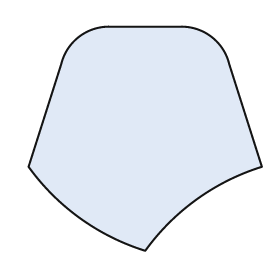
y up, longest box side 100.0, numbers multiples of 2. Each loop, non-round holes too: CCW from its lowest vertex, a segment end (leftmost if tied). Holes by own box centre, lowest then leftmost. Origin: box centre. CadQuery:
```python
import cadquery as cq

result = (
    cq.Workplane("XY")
    .moveTo(0.0, -48.0)
    .threePointArc((22.0, -26.0), (50.0, -12.0))
    .lineTo(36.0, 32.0)
    .threePointArc((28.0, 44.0), (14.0, 48.0))
    .lineTo(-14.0, 48.0)
    .threePointArc((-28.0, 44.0), (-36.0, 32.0))
    .lineTo(-50.0, -12.0)
    .threePointArc((-28.0, -34.0), (0.0, -48.0))
    .close()
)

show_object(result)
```